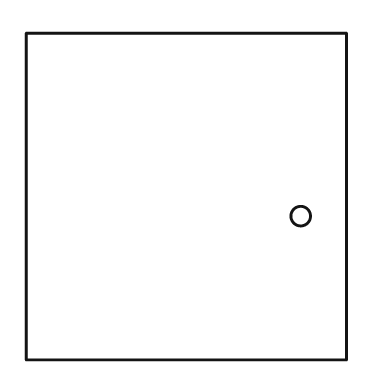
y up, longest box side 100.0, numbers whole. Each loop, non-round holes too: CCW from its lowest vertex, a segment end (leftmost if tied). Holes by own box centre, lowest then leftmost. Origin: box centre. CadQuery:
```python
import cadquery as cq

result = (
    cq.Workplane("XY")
    .moveTo(-49.0, -50.0)
    .lineTo(49.0, -50.0)
    .lineTo(49.0, 50.0)
    .lineTo(-49.0, 50.0)
    .close()
    .moveTo(35.0, -6.0)
    .circle(3.0)
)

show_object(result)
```